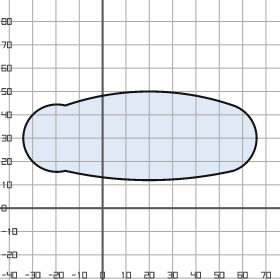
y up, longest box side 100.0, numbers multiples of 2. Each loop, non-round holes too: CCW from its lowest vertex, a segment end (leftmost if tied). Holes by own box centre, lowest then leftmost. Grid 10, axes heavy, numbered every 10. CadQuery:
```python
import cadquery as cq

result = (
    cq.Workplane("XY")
    .moveTo(-16.0, 16.0)
    .threePointArc((20.0, 12.0), (56.0, 16.0))
    .threePointArc((66.0, 30.0), (56.0, 44.0))
    .threePointArc((20.0, 50.0), (-16.0, 44.0))
    .threePointArc((-34.0, 30.0), (-16.0, 16.0))
    .close()
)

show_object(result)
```